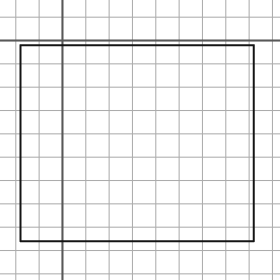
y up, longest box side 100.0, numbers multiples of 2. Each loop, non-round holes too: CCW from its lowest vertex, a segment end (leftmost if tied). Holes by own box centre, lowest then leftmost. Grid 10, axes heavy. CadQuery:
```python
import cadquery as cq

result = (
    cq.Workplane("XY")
    .moveTo(-18.0, -86.0)
    .lineTo(82.0, -86.0)
    .lineTo(82.0, -2.0)
    .lineTo(-18.0, -2.0)
    .close()
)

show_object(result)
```